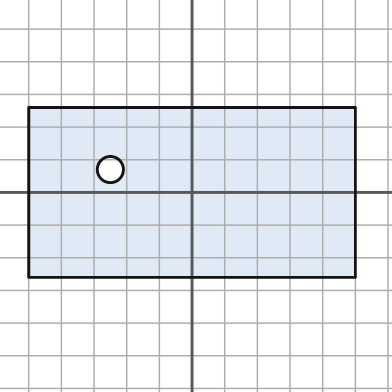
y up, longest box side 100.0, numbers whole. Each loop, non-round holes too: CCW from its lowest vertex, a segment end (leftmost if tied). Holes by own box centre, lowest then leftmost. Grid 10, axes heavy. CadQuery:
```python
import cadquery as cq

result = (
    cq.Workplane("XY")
    .moveTo(-50.0, -26.0)
    .lineTo(50.0, -26.0)
    .lineTo(50.0, 26.0)
    .lineTo(-50.0, 26.0)
    .close()
    .moveTo(-25.0, 7.0)
    .circle(4.0)
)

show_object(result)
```